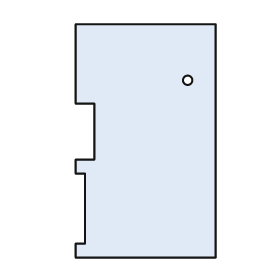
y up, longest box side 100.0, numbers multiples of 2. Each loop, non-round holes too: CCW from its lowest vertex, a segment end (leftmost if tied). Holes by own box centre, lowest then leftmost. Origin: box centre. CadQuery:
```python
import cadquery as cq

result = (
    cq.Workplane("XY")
    .moveTo(-30.0, -50.0)
    .lineTo(30.0, -50.0)
    .lineTo(30.0, 50.0)
    .lineTo(-30.0, 50.0)
    .lineTo(-30.0, 16.0)
    .lineTo(-22.0, 16.0)
    .lineTo(-22.0, -8.0)
    .lineTo(-30.0, -8.0)
    .lineTo(-30.0, -14.0)
    .lineTo(-26.0, -14.0)
    .lineTo(-26.0, -44.0)
    .lineTo(-30.0, -44.0)
    .close()
    .moveTo(18.0, 26.0)
    .circle(2.0)
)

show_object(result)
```